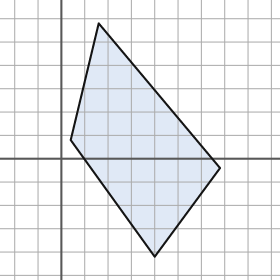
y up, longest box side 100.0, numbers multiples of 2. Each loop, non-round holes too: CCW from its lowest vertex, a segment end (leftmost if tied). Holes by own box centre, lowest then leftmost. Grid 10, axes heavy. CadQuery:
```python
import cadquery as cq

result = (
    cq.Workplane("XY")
    .moveTo(40.0, -42.0)
    .lineTo(68.0, -4.0)
    .lineTo(16.0, 58.0)
    .lineTo(4.0, 8.0)
    .close()
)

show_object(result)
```